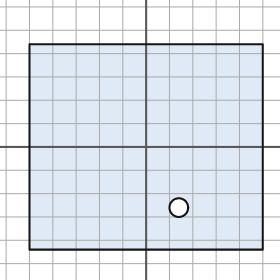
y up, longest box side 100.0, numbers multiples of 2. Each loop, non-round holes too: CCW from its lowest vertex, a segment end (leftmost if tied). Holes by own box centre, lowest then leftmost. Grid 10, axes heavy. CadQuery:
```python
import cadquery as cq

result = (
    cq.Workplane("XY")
    .moveTo(-50.0, -44.0)
    .lineTo(50.0, -44.0)
    .lineTo(50.0, 44.0)
    .lineTo(-50.0, 44.0)
    .close()
    .moveTo(14.0, -26.0)
    .circle(4.0)
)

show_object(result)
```